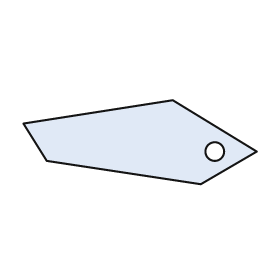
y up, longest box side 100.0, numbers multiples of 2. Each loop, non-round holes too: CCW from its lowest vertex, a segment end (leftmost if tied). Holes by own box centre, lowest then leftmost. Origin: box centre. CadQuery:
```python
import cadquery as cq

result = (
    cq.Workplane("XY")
    .moveTo(26.0, -18.0)
    .lineTo(50.0, -4.0)
    .lineTo(14.0, 18.0)
    .lineTo(-50.0, 8.0)
    .lineTo(-40.0, -8.0)
    .close()
    .moveTo(32.0, -4.0)
    .circle(4.0)
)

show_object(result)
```